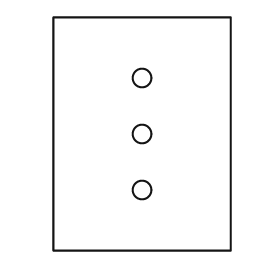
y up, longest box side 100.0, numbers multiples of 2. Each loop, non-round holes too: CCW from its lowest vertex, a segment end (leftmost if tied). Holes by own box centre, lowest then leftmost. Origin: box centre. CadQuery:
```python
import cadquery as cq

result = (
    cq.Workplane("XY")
    .moveTo(-38.0, -50.0)
    .lineTo(38.0, -50.0)
    .lineTo(38.0, 50.0)
    .lineTo(-38.0, 50.0)
    .close()
    .moveTo(0.0, -24.0)
    .circle(4.0)
    .moveTo(0.0, 0.0)
    .circle(4.0)
    .moveTo(0.0, 24.0)
    .circle(4.0)
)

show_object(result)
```